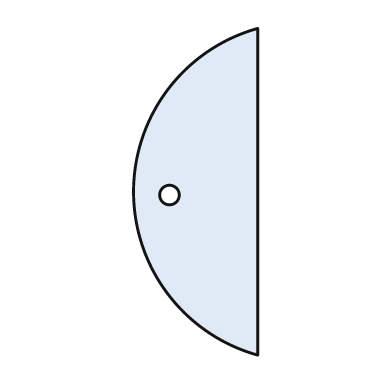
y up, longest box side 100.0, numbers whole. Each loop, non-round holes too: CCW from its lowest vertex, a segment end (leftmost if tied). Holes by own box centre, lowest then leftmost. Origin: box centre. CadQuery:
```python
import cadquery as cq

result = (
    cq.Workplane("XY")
    .moveTo(19.0, -50.0)
    .lineTo(19.0, 50.0)
    .threePointArc((-19.0, 0.0), (19.0, -50.0))
    .close()
    .moveTo(-8.0, -1.0)
    .circle(3.0)
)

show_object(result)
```